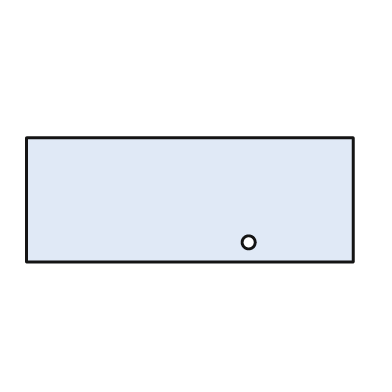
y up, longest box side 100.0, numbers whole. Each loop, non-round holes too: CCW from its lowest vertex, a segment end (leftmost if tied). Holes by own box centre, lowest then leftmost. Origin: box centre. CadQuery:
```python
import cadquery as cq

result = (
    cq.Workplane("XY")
    .moveTo(-50.0, -19.0)
    .lineTo(50.0, -19.0)
    .lineTo(50.0, 19.0)
    .lineTo(-50.0, 19.0)
    .close()
    .moveTo(18.0, -13.0)
    .circle(2.0)
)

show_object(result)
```